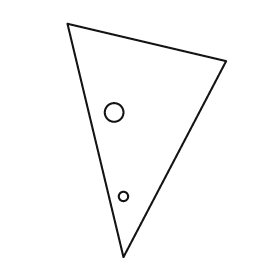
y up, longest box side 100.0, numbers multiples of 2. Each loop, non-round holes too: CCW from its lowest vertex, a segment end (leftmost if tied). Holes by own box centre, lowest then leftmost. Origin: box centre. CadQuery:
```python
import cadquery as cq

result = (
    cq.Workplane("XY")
    .moveTo(-10.0, -50.0)
    .lineTo(34.0, 34.0)
    .lineTo(-34.0, 50.0)
    .close()
    .moveTo(-10.0, -24.0)
    .circle(2.0)
    .moveTo(-14.0, 12.0)
    .circle(4.0)
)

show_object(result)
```